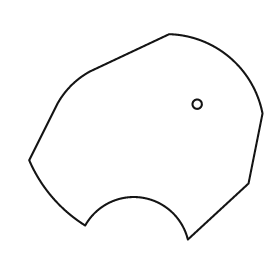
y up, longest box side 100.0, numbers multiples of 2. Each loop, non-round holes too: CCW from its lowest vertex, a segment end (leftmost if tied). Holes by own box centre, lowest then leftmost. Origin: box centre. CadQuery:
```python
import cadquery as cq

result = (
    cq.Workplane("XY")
    .moveTo(18.0, -44.0)
    .lineTo(44.0, -20.0)
    .lineTo(50.0, 10.0)
    .threePointArc((36.0, 34.0), (10.0, 44.0))
    .lineTo(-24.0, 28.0)
    .threePointArc((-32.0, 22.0), (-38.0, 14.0))
    .lineTo(-50.0, -10.0)
    .threePointArc((-40.0, -26.0), (-26.0, -38.0))
    .threePointArc((-2.0, -26.0), (18.0, -44.0))
    .close()
    .moveTo(22.0, 14.0)
    .circle(2.0)
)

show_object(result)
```